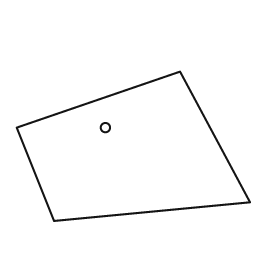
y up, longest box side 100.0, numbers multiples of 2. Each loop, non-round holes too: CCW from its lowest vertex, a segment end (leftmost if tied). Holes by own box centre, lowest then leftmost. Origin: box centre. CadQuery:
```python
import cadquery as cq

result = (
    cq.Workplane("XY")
    .moveTo(-34.0, -32.0)
    .lineTo(50.0, -24.0)
    .lineTo(20.0, 32.0)
    .lineTo(-50.0, 8.0)
    .close()
    .moveTo(-12.0, 8.0)
    .circle(2.0)
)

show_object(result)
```